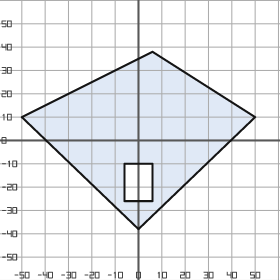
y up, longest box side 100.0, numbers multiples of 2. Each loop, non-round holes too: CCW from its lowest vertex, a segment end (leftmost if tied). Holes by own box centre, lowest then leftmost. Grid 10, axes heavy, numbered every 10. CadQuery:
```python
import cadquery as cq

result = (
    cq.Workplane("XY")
    .moveTo(0.0, -38.0)
    .lineTo(50.0, 10.0)
    .lineTo(6.0, 38.0)
    .lineTo(-50.0, 10.0)
    .close()
    .moveTo(-6.0, -26.0)
    .lineTo(6.0, -26.0)
    .lineTo(6.0, -10.0)
    .lineTo(-6.0, -10.0)
    .close()
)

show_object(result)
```